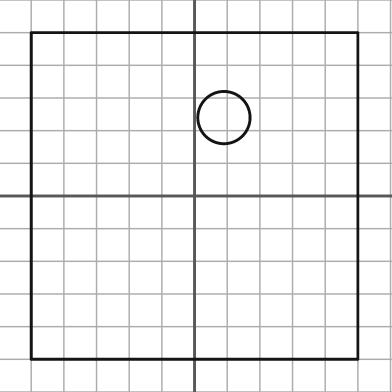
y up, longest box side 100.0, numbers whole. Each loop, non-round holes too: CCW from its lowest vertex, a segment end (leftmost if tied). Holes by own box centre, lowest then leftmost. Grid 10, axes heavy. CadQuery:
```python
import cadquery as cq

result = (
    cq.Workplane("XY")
    .moveTo(-50.0, -50.0)
    .lineTo(50.0, -50.0)
    .lineTo(50.0, 50.0)
    .lineTo(-50.0, 50.0)
    .close()
    .moveTo(9.0, 24.0)
    .circle(8.0)
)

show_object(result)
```